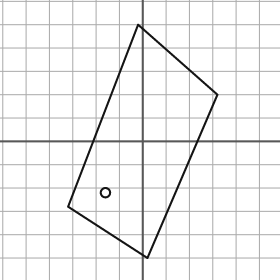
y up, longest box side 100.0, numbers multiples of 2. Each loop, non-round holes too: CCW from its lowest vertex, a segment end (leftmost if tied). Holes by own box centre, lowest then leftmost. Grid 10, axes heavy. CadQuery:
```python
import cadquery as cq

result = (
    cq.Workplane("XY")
    .moveTo(2.0, -50.0)
    .lineTo(32.0, 20.0)
    .lineTo(-2.0, 50.0)
    .lineTo(-32.0, -28.0)
    .close()
    .moveTo(-16.0, -22.0)
    .circle(2.0)
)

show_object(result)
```